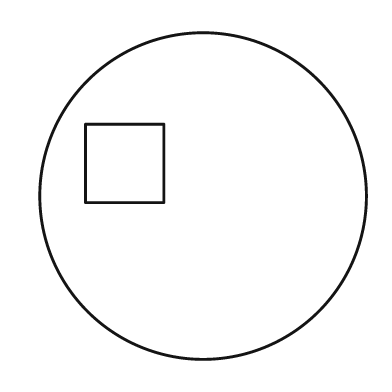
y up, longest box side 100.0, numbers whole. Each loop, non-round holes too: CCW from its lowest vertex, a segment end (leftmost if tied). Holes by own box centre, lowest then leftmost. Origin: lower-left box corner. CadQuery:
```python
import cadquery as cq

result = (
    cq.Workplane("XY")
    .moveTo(50.0, 50.0)
    .circle(50.0)
    .moveTo(14.0, 48.0)
    .lineTo(38.0, 48.0)
    .lineTo(38.0, 72.0)
    .lineTo(14.0, 72.0)
    .close()
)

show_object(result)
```